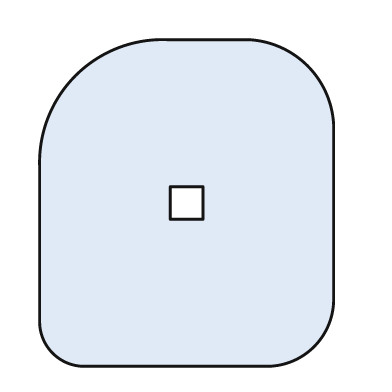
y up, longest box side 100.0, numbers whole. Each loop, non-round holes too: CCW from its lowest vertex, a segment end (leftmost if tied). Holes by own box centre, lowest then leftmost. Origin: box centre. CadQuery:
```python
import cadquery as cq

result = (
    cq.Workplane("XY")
    .moveTo(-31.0, -50.0)
    .lineTo(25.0, -50.0)
    .threePointArc((39.0, -44.0), (45.0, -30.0))
    .lineTo(45.0, 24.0)
    .threePointArc((37.0, 42.0), (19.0, 50.0))
    .lineTo(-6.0, 50.0)
    .threePointArc((-34.0, 39.0), (-45.0, 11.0))
    .lineTo(-45.0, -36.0)
    .threePointArc((-41.0, -46.0), (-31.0, -50.0))
    .close()
    .moveTo(-5.0, -5.0)
    .lineTo(5.0, -5.0)
    .lineTo(5.0, 5.0)
    .lineTo(-5.0, 5.0)
    .close()
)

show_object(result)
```